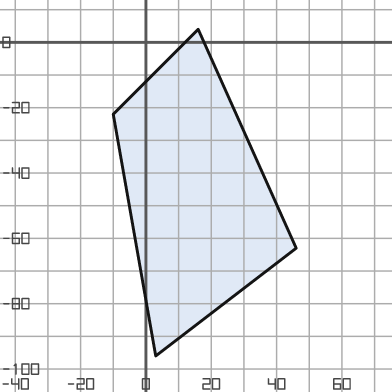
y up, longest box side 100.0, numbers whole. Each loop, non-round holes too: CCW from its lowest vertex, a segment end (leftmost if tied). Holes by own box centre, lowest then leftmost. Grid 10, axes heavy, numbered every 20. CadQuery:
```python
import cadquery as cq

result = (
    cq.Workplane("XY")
    .moveTo(3.0, -96.0)
    .lineTo(46.0, -63.0)
    .lineTo(16.0, 4.0)
    .lineTo(-10.0, -22.0)
    .close()
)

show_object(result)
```